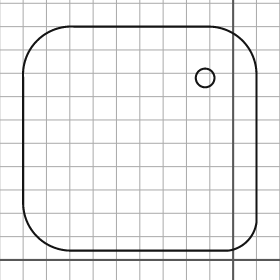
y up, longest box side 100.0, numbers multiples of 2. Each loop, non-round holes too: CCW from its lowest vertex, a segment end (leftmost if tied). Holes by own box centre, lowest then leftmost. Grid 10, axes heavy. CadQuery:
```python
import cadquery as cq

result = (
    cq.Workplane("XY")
    .moveTo(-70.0, 4.0)
    .lineTo(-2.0, 4.0)
    .threePointArc((6.0, 8.0), (10.0, 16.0))
    .lineTo(10.0, 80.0)
    .threePointArc((4.0, 94.0), (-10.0, 100.0))
    .lineTo(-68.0, 100.0)
    .threePointArc((-84.0, 94.0), (-90.0, 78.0))
    .lineTo(-90.0, 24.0)
    .threePointArc((-84.0, 10.0), (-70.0, 4.0))
    .close()
    .moveTo(-12.0, 78.0)
    .circle(4.0)
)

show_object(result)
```